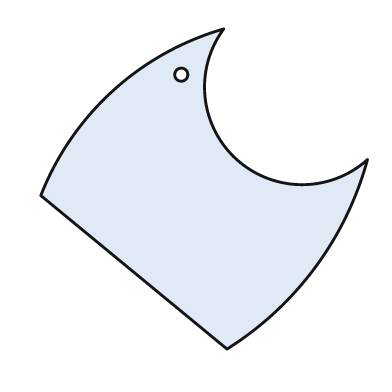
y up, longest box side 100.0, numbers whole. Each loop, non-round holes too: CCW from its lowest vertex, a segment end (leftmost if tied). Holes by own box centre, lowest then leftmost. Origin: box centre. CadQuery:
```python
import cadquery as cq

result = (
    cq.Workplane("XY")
    .moveTo(7.0, -49.0)
    .threePointArc((34.0, -24.0), (50.0, 9.0))
    .threePointArc((10.0, 9.0), (6.0, 49.0))
    .threePointArc((-28.0, 30.0), (-50.0, -2.0))
    .close()
    .moveTo(-7.0, 35.0)
    .circle(2.0)
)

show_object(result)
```